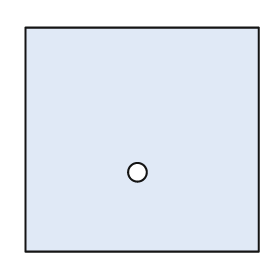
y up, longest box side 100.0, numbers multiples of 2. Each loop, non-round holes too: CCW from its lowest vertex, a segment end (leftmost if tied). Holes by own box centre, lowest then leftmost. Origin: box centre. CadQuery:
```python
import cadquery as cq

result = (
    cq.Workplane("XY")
    .moveTo(-50.0, -48.0)
    .lineTo(50.0, -48.0)
    .lineTo(50.0, 48.0)
    .lineTo(-50.0, 48.0)
    .close()
    .moveTo(-2.0, -14.0)
    .circle(4.0)
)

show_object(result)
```